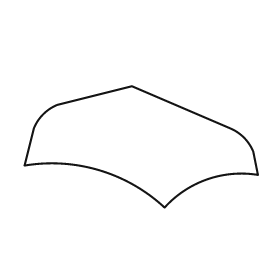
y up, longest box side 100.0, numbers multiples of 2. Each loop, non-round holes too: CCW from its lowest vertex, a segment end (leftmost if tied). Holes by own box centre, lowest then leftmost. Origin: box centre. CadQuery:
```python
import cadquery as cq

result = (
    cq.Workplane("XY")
    .moveTo(10.0, -26.0)
    .threePointArc((28.0, -14.0), (50.0, -12.0))
    .lineTo(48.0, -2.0)
    .threePointArc((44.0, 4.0), (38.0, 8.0))
    .lineTo(-4.0, 26.0)
    .lineTo(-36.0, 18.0)
    .threePointArc((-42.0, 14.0), (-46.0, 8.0))
    .lineTo(-50.0, -8.0)
    .threePointArc((-18.0, -10.0), (10.0, -26.0))
    .close()
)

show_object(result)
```